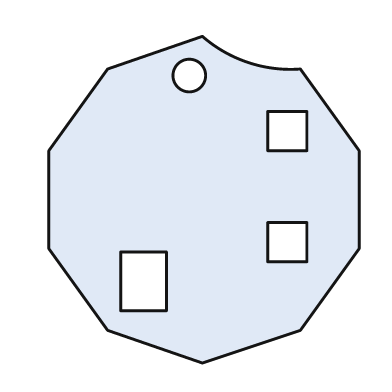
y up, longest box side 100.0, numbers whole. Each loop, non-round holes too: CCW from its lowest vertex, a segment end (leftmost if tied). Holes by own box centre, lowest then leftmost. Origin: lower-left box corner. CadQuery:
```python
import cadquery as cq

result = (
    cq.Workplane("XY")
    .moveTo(47.0, 0.0)
    .lineTo(77.0, 10.0)
    .lineTo(95.0, 35.0)
    .lineTo(95.0, 65.0)
    .lineTo(77.0, 90.0)
    .threePointArc((61.0, 92.0), (47.0, 100.0))
    .lineTo(18.0, 90.0)
    .lineTo(0.0, 65.0)
    .lineTo(0.0, 35.0)
    .lineTo(18.0, 10.0)
    .close()
    .moveTo(22.0, 16.0)
    .lineTo(36.0, 16.0)
    .lineTo(36.0, 34.0)
    .lineTo(22.0, 34.0)
    .close()
    .moveTo(67.0, 31.0)
    .lineTo(79.0, 31.0)
    .lineTo(79.0, 43.0)
    .lineTo(67.0, 43.0)
    .close()
    .moveTo(67.0, 65.0)
    .lineTo(79.0, 65.0)
    .lineTo(79.0, 77.0)
    .lineTo(67.0, 77.0)
    .close()
    .moveTo(43.0, 88.0)
    .circle(5.0)
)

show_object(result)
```